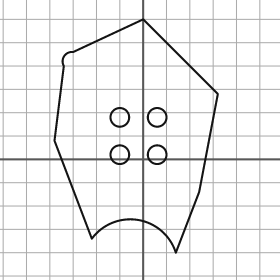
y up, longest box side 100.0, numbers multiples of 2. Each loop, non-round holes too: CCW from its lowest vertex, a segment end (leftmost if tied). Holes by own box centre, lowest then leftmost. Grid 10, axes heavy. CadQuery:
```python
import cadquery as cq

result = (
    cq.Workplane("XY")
    .moveTo(14.0, -40.0)
    .lineTo(24.0, -14.0)
    .lineTo(32.0, 28.0)
    .lineTo(0.0, 60.0)
    .lineTo(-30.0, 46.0)
    .threePointArc((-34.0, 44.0), (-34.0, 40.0))
    .lineTo(-38.0, 8.0)
    .lineTo(-22.0, -34.0)
    .threePointArc((-2.0, -26.0), (14.0, -40.0))
    .close()
    .moveTo(-10.0, 2.0)
    .circle(4.0)
    .moveTo(6.0, 2.0)
    .circle(4.0)
    .moveTo(-10.0, 18.0)
    .circle(4.0)
    .moveTo(6.0, 18.0)
    .circle(4.0)
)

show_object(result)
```